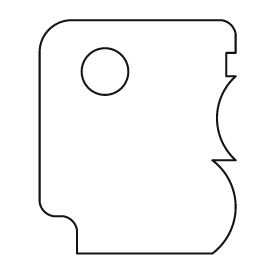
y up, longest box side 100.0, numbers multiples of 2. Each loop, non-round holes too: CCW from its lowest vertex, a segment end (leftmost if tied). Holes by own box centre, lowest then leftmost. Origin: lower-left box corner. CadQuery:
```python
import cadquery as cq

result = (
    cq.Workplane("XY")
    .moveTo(16.0, 0.0)
    .lineTo(74.0, 0.0)
    .threePointArc((84.0, 20.0), (74.0, 40.0))
    .lineTo(84.0, 40.0)
    .threePointArc((76.0, 58.0), (84.0, 76.0))
    .lineTo(80.0, 76.0)
    .lineTo(80.0, 86.0)
    .lineTo(84.0, 86.0)
    .lineTo(84.0, 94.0)
    .threePointArc((82.0, 98.0), (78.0, 100.0))
    .lineTo(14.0, 100.0)
    .threePointArc((4.0, 96.0), (0.0, 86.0))
    .lineTo(0.0, 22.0)
    .threePointArc((2.0, 18.0), (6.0, 16.0))
    .lineTo(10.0, 16.0)
    .threePointArc((14.0, 14.0), (16.0, 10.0))
    .close()
    .moveTo(28.0, 78.0)
    .circle(10.0)
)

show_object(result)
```